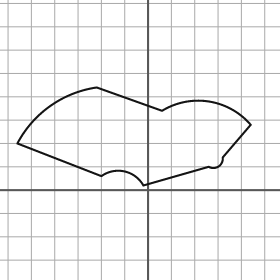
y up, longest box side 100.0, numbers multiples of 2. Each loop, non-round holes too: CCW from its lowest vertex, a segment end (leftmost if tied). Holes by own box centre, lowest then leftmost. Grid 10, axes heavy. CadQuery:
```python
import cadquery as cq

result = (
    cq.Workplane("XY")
    .moveTo(-2.0, 2.0)
    .lineTo(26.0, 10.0)
    .threePointArc((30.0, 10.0), (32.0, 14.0))
    .lineTo(44.0, 28.0)
    .threePointArc((26.0, 38.0), (6.0, 34.0))
    .lineTo(-22.0, 44.0)
    .threePointArc((-42.0, 36.0), (-56.0, 20.0))
    .lineTo(-20.0, 6.0)
    .threePointArc((-10.0, 8.0), (-2.0, 2.0))
    .close()
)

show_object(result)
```